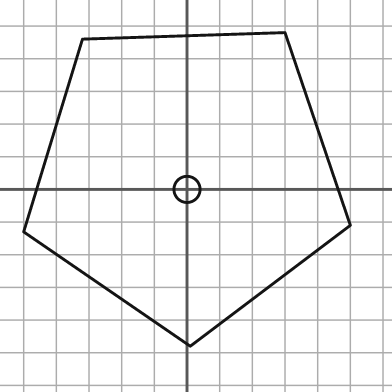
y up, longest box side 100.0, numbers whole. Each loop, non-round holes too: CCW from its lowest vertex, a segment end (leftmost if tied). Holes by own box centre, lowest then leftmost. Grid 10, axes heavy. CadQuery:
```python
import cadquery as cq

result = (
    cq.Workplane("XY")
    .moveTo(1.0, -48.0)
    .lineTo(50.0, -11.0)
    .lineTo(30.0, 48.0)
    .lineTo(-32.0, 46.0)
    .lineTo(-50.0, -13.0)
    .close()
    .moveTo(0.0, 0.0)
    .circle(4.0)
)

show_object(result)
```